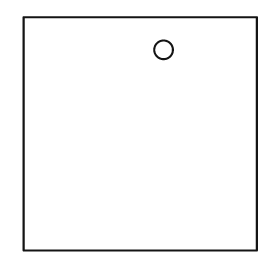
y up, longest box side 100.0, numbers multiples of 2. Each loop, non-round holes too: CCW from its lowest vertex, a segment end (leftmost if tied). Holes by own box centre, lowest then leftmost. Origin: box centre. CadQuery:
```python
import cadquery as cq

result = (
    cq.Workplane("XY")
    .moveTo(-50.0, -50.0)
    .lineTo(50.0, -50.0)
    .lineTo(50.0, 50.0)
    .lineTo(-50.0, 50.0)
    .close()
    .moveTo(10.0, 36.0)
    .circle(4.0)
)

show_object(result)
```